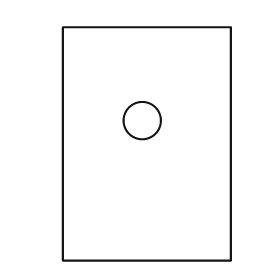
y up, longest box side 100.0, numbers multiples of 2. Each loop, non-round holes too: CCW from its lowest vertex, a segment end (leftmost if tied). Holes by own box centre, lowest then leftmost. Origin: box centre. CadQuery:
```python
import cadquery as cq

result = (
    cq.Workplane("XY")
    .moveTo(-36.0, -50.0)
    .lineTo(36.0, -50.0)
    .lineTo(36.0, 50.0)
    .lineTo(-36.0, 50.0)
    .close()
    .moveTo(-2.0, 10.0)
    .circle(8.0)
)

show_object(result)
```